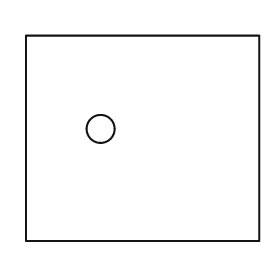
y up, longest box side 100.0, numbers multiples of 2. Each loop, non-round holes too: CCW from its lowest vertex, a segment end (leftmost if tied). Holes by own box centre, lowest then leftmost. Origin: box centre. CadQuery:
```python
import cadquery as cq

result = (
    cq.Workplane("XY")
    .moveTo(-50.0, -44.0)
    .lineTo(50.0, -44.0)
    .lineTo(50.0, 44.0)
    .lineTo(-50.0, 44.0)
    .close()
    .moveTo(-18.0, 4.0)
    .circle(6.0)
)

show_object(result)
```